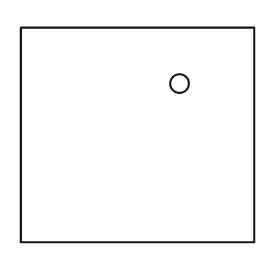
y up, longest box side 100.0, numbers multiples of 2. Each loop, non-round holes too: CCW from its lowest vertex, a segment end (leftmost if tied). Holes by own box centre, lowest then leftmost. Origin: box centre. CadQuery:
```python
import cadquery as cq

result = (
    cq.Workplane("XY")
    .moveTo(-50.0, -46.0)
    .lineTo(50.0, -46.0)
    .lineTo(50.0, 46.0)
    .lineTo(-50.0, 46.0)
    .close()
    .moveTo(18.0, 22.0)
    .circle(4.0)
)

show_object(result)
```